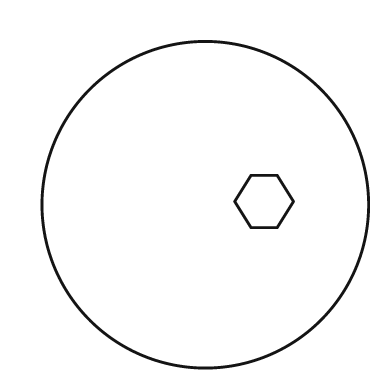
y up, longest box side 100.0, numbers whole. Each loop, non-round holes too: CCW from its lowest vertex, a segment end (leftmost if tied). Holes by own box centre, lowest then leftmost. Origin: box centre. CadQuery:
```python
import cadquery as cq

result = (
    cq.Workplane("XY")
    .moveTo(0.0, 0.0)
    .circle(50.0)
    .moveTo(14.0, -7.0)
    .lineTo(22.0, -7.0)
    .lineTo(27.0, 1.0)
    .lineTo(22.0, 9.0)
    .lineTo(14.0, 9.0)
    .lineTo(9.0, 1.0)
    .close()
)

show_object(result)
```